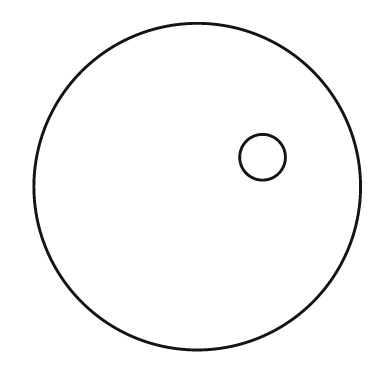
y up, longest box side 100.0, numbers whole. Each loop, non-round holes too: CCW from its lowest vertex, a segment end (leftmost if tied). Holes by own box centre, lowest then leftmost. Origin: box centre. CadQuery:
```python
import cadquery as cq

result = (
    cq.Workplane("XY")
    .moveTo(0.0, 0.0)
    .circle(50.0)
    .moveTo(20.0, 9.0)
    .circle(7.0)
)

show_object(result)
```